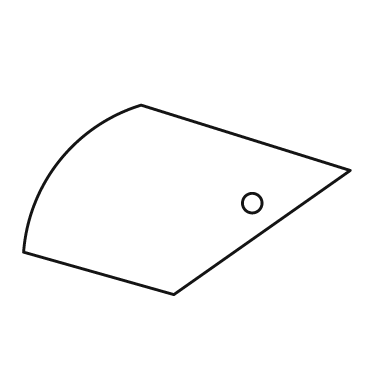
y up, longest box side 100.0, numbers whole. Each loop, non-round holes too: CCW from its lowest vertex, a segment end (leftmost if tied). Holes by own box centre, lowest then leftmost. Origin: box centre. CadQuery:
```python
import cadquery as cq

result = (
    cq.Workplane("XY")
    .moveTo(-4.0, -29.0)
    .lineTo(50.0, 9.0)
    .lineTo(-14.0, 29.0)
    .threePointArc((-39.0, 12.0), (-50.0, -16.0))
    .close()
    .moveTo(20.0, -1.0)
    .circle(3.0)
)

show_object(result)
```